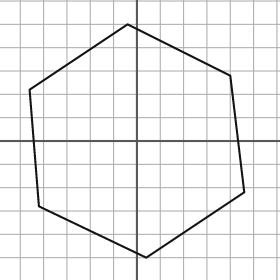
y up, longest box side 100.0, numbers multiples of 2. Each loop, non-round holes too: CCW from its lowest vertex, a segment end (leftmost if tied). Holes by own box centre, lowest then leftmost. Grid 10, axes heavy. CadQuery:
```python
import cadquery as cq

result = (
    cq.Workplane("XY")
    .moveTo(4.0, -50.0)
    .lineTo(46.0, -22.0)
    .lineTo(40.0, 28.0)
    .lineTo(-4.0, 50.0)
    .lineTo(-46.0, 22.0)
    .lineTo(-42.0, -28.0)
    .close()
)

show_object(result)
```